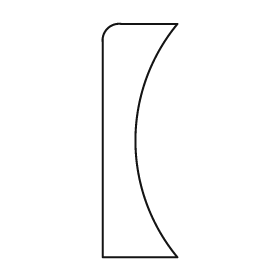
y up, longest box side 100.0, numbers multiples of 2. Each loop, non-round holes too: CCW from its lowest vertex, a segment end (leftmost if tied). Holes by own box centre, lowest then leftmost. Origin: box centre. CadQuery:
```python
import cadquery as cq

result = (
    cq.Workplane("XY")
    .moveTo(-16.0, -50.0)
    .lineTo(16.0, -50.0)
    .threePointArc((-2.0, 0.0), (16.0, 50.0))
    .lineTo(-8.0, 50.0)
    .threePointArc((-14.0, 48.0), (-16.0, 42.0))
    .close()
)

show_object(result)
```